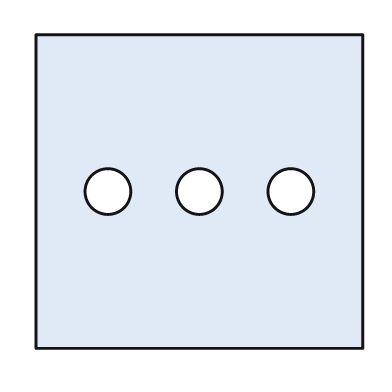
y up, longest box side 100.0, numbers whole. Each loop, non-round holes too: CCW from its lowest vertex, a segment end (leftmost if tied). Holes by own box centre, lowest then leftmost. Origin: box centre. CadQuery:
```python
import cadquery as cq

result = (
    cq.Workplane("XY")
    .moveTo(-50.0, -48.0)
    .lineTo(50.0, -48.0)
    .lineTo(50.0, 48.0)
    .lineTo(-50.0, 48.0)
    .close()
    .moveTo(-28.0, 0.0)
    .circle(7.0)
    .moveTo(0.0, 0.0)
    .circle(7.0)
    .moveTo(28.0, 0.0)
    .circle(7.0)
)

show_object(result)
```